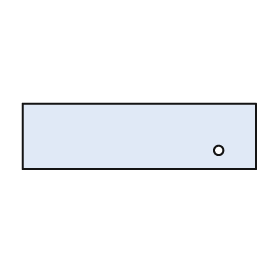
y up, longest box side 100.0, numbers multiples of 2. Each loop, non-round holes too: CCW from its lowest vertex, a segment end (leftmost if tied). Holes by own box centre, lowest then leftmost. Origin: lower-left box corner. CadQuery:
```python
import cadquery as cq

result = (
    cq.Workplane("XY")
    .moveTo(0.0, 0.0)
    .lineTo(100.0, 0.0)
    .lineTo(100.0, 28.0)
    .lineTo(0.0, 28.0)
    .close()
    .moveTo(84.0, 8.0)
    .circle(2.0)
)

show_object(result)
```